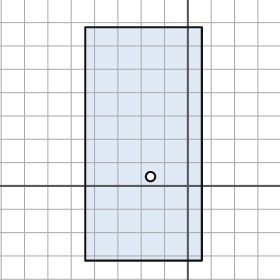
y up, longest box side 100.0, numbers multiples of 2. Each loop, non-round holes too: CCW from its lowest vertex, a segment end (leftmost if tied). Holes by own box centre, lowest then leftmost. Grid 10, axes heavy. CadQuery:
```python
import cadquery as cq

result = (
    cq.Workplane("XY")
    .moveTo(-44.0, -32.0)
    .lineTo(6.0, -32.0)
    .lineTo(6.0, 68.0)
    .lineTo(-44.0, 68.0)
    .close()
    .moveTo(-16.0, 4.0)
    .circle(2.0)
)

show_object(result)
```